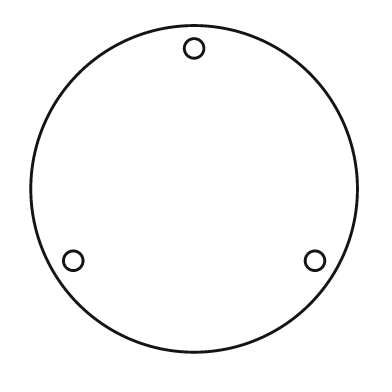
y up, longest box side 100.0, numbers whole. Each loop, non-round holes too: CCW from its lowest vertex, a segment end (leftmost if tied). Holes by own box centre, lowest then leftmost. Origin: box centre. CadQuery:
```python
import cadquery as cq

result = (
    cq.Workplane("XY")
    .moveTo(0.0, 0.0)
    .circle(50.0)
    .moveTo(-37.0, -22.0)
    .circle(3.0)
    .moveTo(37.0, -22.0)
    .circle(3.0)
    .moveTo(0.0, 43.0)
    .circle(3.0)
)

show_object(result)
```